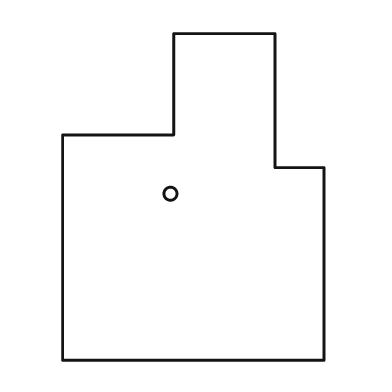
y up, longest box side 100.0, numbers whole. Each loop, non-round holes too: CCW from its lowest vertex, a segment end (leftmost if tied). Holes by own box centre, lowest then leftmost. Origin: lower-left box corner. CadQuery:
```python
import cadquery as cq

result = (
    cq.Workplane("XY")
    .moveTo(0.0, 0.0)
    .lineTo(80.0, 0.0)
    .lineTo(80.0, 59.0)
    .lineTo(65.0, 59.0)
    .lineTo(65.0, 100.0)
    .lineTo(34.0, 100.0)
    .lineTo(34.0, 69.0)
    .lineTo(0.0, 69.0)
    .close()
    .moveTo(33.0, 51.0)
    .circle(2.0)
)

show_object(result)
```